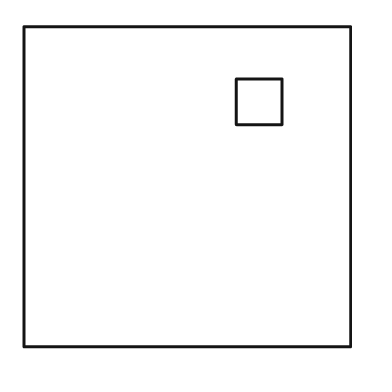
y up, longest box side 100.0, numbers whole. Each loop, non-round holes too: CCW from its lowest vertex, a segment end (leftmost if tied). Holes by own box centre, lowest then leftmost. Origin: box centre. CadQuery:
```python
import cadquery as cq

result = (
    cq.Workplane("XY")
    .moveTo(-50.0, -49.0)
    .lineTo(50.0, -49.0)
    .lineTo(50.0, 49.0)
    .lineTo(-50.0, 49.0)
    .close()
    .moveTo(15.0, 19.0)
    .lineTo(29.0, 19.0)
    .lineTo(29.0, 33.0)
    .lineTo(15.0, 33.0)
    .close()
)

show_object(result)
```